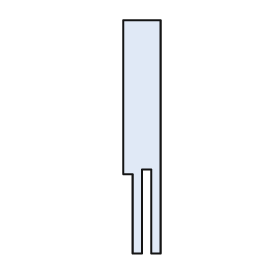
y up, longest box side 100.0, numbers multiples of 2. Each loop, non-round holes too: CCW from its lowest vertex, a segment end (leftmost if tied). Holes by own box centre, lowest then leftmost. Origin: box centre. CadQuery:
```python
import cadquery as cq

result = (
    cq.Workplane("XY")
    .moveTo(-4.0, -50.0)
    .lineTo(0.0, -50.0)
    .lineTo(0.0, -14.0)
    .lineTo(4.0, -14.0)
    .lineTo(4.0, -50.0)
    .lineTo(8.0, -50.0)
    .lineTo(8.0, 50.0)
    .lineTo(-8.0, 50.0)
    .lineTo(-8.0, -16.0)
    .lineTo(-4.0, -16.0)
    .close()
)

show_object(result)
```